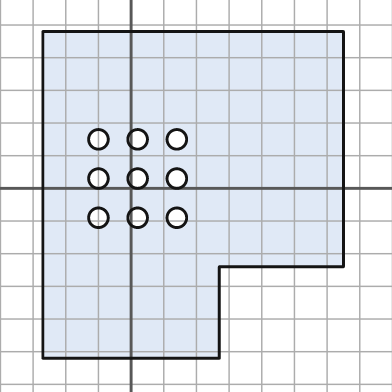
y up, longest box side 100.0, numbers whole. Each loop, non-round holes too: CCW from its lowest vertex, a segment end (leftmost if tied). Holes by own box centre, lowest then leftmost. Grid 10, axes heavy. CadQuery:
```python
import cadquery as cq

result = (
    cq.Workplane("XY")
    .moveTo(-27.0, -52.0)
    .lineTo(27.0, -52.0)
    .lineTo(27.0, -24.0)
    .lineTo(65.0, -24.0)
    .lineTo(65.0, 48.0)
    .lineTo(-27.0, 48.0)
    .close()
    .moveTo(-10.0, -9.0)
    .circle(3.0)
    .moveTo(2.0, -9.0)
    .circle(3.0)
    .moveTo(14.0, -9.0)
    .circle(3.0)
    .moveTo(-10.0, 3.0)
    .circle(3.0)
    .moveTo(2.0, 3.0)
    .circle(3.0)
    .moveTo(14.0, 3.0)
    .circle(3.0)
    .moveTo(-10.0, 15.0)
    .circle(3.0)
    .moveTo(2.0, 15.0)
    .circle(3.0)
    .moveTo(14.0, 15.0)
    .circle(3.0)
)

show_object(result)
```